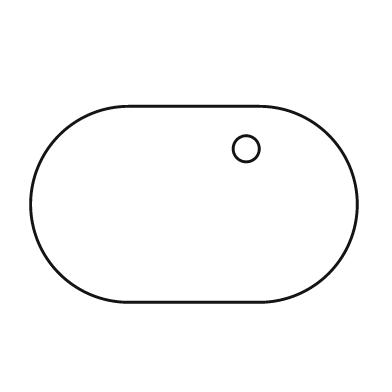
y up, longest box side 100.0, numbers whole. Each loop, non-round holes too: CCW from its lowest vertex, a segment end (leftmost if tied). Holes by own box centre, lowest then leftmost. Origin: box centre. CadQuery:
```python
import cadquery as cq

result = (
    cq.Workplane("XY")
    .moveTo(-20.0, -30.0)
    .lineTo(20.0, -30.0)
    .threePointArc((50.0, 0.0), (20.0, 30.0))
    .lineTo(-20.0, 30.0)
    .threePointArc((-50.0, 0.0), (-20.0, -30.0))
    .close()
    .moveTo(16.0, 17.0)
    .circle(4.0)
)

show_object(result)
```